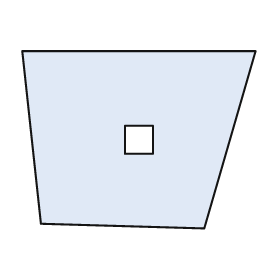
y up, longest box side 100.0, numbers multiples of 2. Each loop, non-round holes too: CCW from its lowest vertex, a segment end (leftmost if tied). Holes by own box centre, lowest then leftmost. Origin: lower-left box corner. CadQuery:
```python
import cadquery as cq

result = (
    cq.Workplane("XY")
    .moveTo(78.0, 0.0)
    .lineTo(100.0, 76.0)
    .lineTo(0.0, 76.0)
    .lineTo(8.0, 2.0)
    .close()
    .moveTo(44.0, 32.0)
    .lineTo(56.0, 32.0)
    .lineTo(56.0, 44.0)
    .lineTo(44.0, 44.0)
    .close()
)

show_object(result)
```